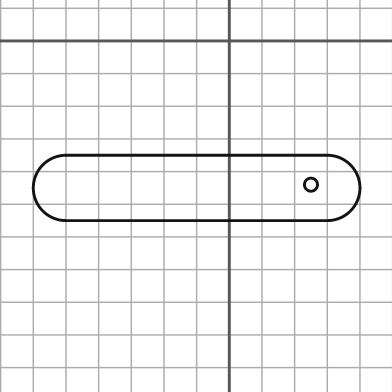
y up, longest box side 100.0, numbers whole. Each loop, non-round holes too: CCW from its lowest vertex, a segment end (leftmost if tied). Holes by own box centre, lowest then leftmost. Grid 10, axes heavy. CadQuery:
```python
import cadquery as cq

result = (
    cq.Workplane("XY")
    .moveTo(-50.0, -55.0)
    .lineTo(30.0, -55.0)
    .threePointArc((40.0, -45.0), (30.0, -35.0))
    .lineTo(-50.0, -35.0)
    .threePointArc((-60.0, -45.0), (-50.0, -55.0))
    .close()
    .moveTo(25.0, -44.0)
    .circle(2.0)
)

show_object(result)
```